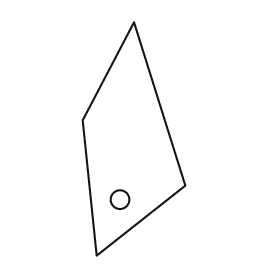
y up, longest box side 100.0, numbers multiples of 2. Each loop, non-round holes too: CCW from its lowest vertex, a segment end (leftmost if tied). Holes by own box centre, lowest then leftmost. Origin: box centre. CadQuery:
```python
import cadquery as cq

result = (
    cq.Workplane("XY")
    .moveTo(-16.0, -50.0)
    .lineTo(22.0, -20.0)
    .lineTo(0.0, 50.0)
    .lineTo(-22.0, 8.0)
    .close()
    .moveTo(-6.0, -26.0)
    .circle(4.0)
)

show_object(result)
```